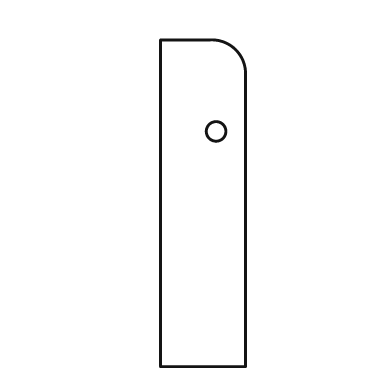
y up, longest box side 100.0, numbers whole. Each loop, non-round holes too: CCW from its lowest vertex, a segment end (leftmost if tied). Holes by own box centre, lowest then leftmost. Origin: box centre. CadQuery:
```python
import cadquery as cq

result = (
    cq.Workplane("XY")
    .moveTo(-13.0, -50.0)
    .lineTo(13.0, -50.0)
    .lineTo(13.0, 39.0)
    .threePointArc((10.0, 47.0), (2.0, 50.0))
    .lineTo(-13.0, 50.0)
    .close()
    .moveTo(4.0, 22.0)
    .circle(3.0)
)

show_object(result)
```